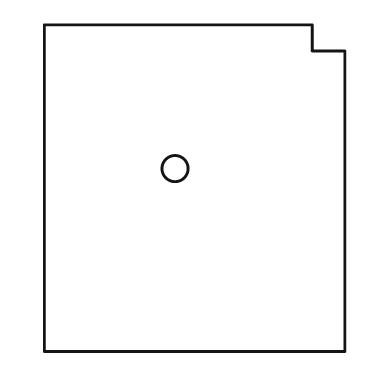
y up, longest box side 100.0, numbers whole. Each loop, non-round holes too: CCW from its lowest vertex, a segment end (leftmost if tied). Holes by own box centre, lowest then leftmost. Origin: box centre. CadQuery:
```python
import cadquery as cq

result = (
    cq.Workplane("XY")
    .moveTo(-46.0, -50.0)
    .lineTo(46.0, -50.0)
    .lineTo(46.0, 42.0)
    .lineTo(36.0, 42.0)
    .lineTo(36.0, 50.0)
    .lineTo(-46.0, 50.0)
    .close()
    .moveTo(-6.0, 6.0)
    .circle(4.0)
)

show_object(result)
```